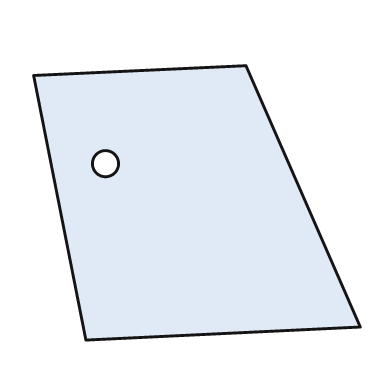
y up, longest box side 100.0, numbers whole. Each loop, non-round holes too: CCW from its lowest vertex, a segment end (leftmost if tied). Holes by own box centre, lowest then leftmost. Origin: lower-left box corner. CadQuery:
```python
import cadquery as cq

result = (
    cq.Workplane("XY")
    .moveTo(16.0, 0.0)
    .lineTo(100.0, 4.0)
    .lineTo(65.0, 84.0)
    .lineTo(0.0, 81.0)
    .close()
    .moveTo(22.0, 54.0)
    .circle(4.0)
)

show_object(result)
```